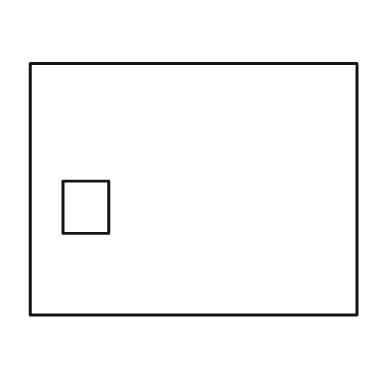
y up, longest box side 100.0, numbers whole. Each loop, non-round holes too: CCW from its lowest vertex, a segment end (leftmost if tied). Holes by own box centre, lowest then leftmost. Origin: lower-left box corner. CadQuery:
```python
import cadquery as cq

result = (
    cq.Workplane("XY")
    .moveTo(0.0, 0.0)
    .lineTo(100.0, 0.0)
    .lineTo(100.0, 77.0)
    .lineTo(0.0, 77.0)
    .close()
    .moveTo(10.0, 25.0)
    .lineTo(24.0, 25.0)
    .lineTo(24.0, 41.0)
    .lineTo(10.0, 41.0)
    .close()
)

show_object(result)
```